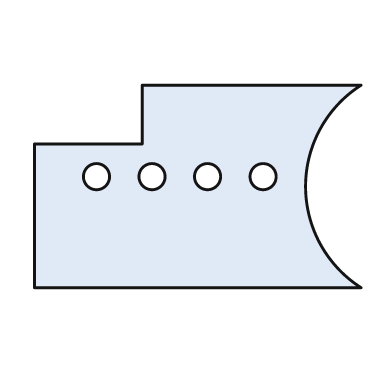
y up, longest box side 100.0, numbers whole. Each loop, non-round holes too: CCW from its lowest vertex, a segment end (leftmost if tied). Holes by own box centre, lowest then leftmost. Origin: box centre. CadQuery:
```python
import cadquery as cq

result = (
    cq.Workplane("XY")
    .moveTo(-50.0, -31.0)
    .lineTo(50.0, -31.0)
    .threePointArc((33.0, 0.0), (50.0, 31.0))
    .lineTo(-17.0, 31.0)
    .lineTo(-17.0, 13.0)
    .lineTo(-50.0, 13.0)
    .close()
    .moveTo(-31.0, 3.0)
    .circle(4.0)
    .moveTo(-14.0, 3.0)
    .circle(4.0)
    .moveTo(3.0, 3.0)
    .circle(4.0)
    .moveTo(20.0, 3.0)
    .circle(4.0)
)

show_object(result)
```